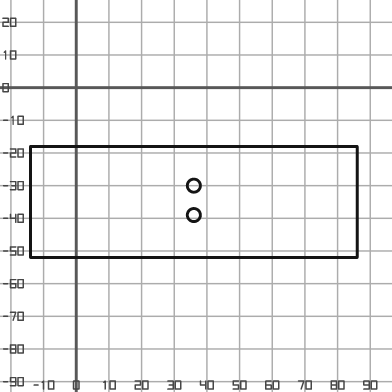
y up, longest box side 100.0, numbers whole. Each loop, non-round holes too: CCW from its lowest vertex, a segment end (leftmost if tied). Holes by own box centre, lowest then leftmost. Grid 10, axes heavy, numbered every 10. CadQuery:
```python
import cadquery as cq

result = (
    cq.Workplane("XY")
    .moveTo(-14.0, -52.0)
    .lineTo(86.0, -52.0)
    .lineTo(86.0, -18.0)
    .lineTo(-14.0, -18.0)
    .close()
    .moveTo(36.0, -39.0)
    .circle(2.0)
    .moveTo(36.0, -30.0)
    .circle(2.0)
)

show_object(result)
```